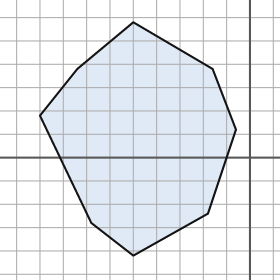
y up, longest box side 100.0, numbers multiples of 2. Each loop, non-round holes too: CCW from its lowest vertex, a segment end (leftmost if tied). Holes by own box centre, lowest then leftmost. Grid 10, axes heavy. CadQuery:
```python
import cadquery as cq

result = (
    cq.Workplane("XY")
    .moveTo(-50.0, -42.0)
    .lineTo(-18.0, -24.0)
    .lineTo(-6.0, 12.0)
    .lineTo(-16.0, 38.0)
    .lineTo(-50.0, 58.0)
    .lineTo(-74.0, 38.0)
    .lineTo(-90.0, 18.0)
    .lineTo(-68.0, -28.0)
    .close()
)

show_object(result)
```